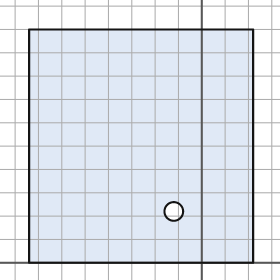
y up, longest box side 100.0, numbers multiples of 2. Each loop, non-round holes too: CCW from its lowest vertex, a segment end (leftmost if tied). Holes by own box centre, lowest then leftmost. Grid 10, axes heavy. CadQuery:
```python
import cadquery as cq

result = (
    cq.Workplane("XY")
    .moveTo(-74.0, 0.0)
    .lineTo(22.0, 0.0)
    .lineTo(22.0, 100.0)
    .lineTo(-74.0, 100.0)
    .close()
    .moveTo(-12.0, 22.0)
    .circle(4.0)
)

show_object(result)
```